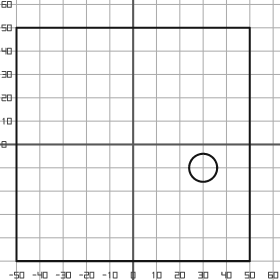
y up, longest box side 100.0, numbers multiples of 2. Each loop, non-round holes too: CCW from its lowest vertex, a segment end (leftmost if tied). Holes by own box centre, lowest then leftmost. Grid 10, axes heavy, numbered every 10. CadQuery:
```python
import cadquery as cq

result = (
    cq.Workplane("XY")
    .moveTo(-50.0, -50.0)
    .lineTo(50.0, -50.0)
    .lineTo(50.0, 50.0)
    .lineTo(-50.0, 50.0)
    .close()
    .moveTo(30.0, -10.0)
    .circle(6.0)
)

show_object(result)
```